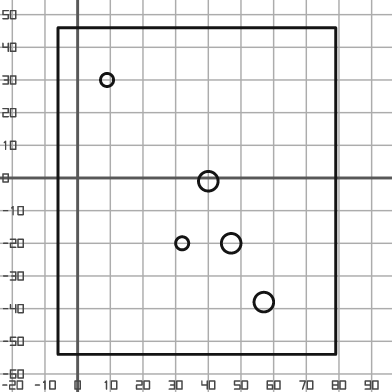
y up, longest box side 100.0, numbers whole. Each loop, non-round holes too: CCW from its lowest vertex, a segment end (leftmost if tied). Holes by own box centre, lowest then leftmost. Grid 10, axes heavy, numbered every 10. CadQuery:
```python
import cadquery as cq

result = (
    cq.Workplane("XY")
    .moveTo(-6.0, -54.0)
    .lineTo(79.0, -54.0)
    .lineTo(79.0, 46.0)
    .lineTo(-6.0, 46.0)
    .close()
    .moveTo(57.0, -38.0)
    .circle(3.0)
    .moveTo(32.0, -20.0)
    .circle(2.0)
    .moveTo(47.0, -20.0)
    .circle(3.0)
    .moveTo(40.0, -1.0)
    .circle(3.0)
    .moveTo(9.0, 30.0)
    .circle(2.0)
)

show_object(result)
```